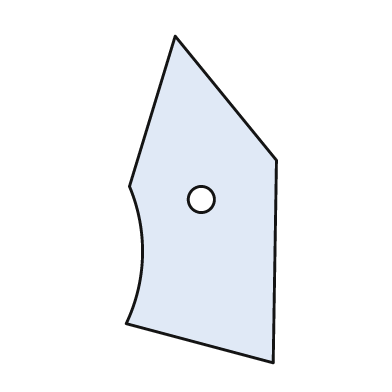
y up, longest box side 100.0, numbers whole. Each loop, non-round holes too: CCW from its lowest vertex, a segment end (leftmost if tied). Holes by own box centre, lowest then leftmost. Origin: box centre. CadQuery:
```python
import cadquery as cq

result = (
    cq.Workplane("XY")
    .moveTo(22.0, -50.0)
    .lineTo(23.0, 12.0)
    .lineTo(-8.0, 50.0)
    .lineTo(-22.0, 4.0)
    .threePointArc((-18.0, -17.0), (-23.0, -38.0))
    .close()
    .moveTo(0.0, 0.0)
    .circle(4.0)
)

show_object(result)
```